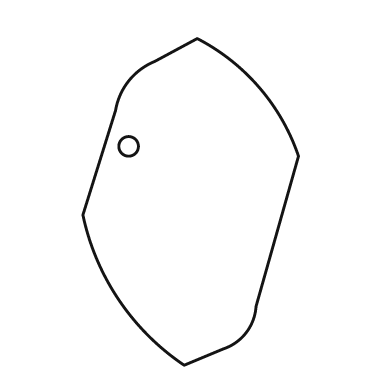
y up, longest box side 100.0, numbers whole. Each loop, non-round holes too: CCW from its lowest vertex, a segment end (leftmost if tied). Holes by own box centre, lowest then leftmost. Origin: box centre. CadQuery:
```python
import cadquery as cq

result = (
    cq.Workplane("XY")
    .moveTo(-2.0, -50.0)
    .lineTo(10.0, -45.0)
    .threePointArc((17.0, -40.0), (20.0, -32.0))
    .lineTo(33.0, 14.0)
    .threePointArc((21.0, 35.0), (2.0, 50.0))
    .lineTo(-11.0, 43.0)
    .threePointArc((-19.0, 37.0), (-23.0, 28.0))
    .lineTo(-33.0, -4.0)
    .threePointArc((-22.0, -30.0), (-2.0, -50.0))
    .close()
    .moveTo(-19.0, 17.0)
    .circle(3.0)
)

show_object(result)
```